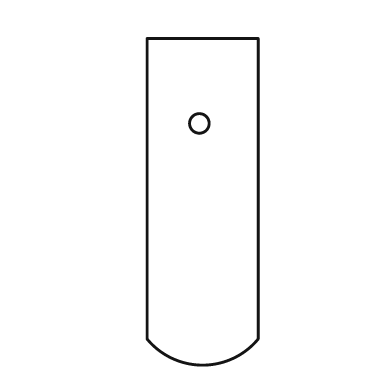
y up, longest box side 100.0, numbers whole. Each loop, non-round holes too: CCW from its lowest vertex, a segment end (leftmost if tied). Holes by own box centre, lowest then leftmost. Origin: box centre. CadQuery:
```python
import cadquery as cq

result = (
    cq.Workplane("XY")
    .moveTo(-17.0, -42.0)
    .threePointArc((0.0, -50.0), (17.0, -42.0))
    .lineTo(17.0, 50.0)
    .lineTo(-17.0, 50.0)
    .close()
    .moveTo(-1.0, 24.0)
    .circle(3.0)
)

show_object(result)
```